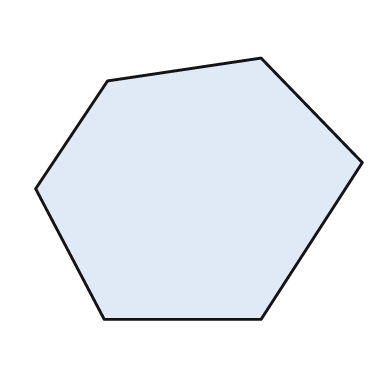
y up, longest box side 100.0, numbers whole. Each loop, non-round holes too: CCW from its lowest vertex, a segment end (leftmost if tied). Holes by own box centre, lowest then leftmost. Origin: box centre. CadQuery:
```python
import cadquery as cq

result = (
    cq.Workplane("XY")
    .moveTo(-29.0, -40.0)
    .lineTo(19.0, -40.0)
    .lineTo(50.0, 8.0)
    .lineTo(19.0, 40.0)
    .lineTo(-28.0, 33.0)
    .lineTo(-50.0, 0.0)
    .close()
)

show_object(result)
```